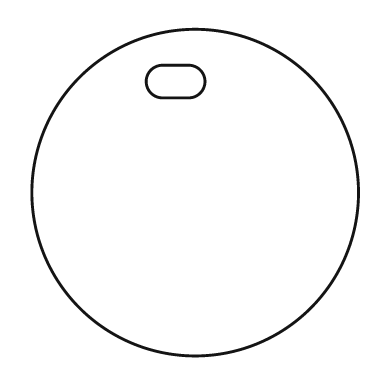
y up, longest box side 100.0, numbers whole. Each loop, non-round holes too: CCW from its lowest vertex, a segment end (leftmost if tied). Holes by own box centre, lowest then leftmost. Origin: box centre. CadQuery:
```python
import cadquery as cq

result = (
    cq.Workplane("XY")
    .moveTo(0.0, 0.0)
    .circle(50.0)
    .moveTo(-10.0, 29.0)
    .lineTo(-2.0, 29.0)
    .threePointArc((3.0, 34.0), (-2.0, 39.0))
    .lineTo(-10.0, 39.0)
    .threePointArc((-15.0, 34.0), (-10.0, 29.0))
    .close()
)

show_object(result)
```